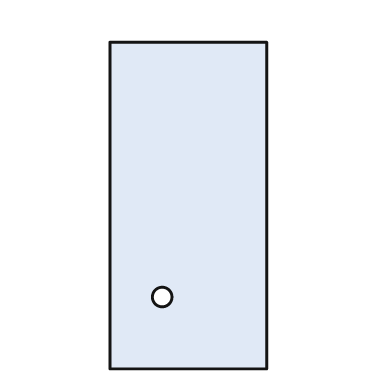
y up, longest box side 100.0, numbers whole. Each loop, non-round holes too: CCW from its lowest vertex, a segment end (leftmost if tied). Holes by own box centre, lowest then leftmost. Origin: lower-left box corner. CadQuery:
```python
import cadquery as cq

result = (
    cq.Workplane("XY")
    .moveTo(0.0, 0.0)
    .lineTo(48.0, 0.0)
    .lineTo(48.0, 100.0)
    .lineTo(0.0, 100.0)
    .close()
    .moveTo(16.0, 22.0)
    .circle(3.0)
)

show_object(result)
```